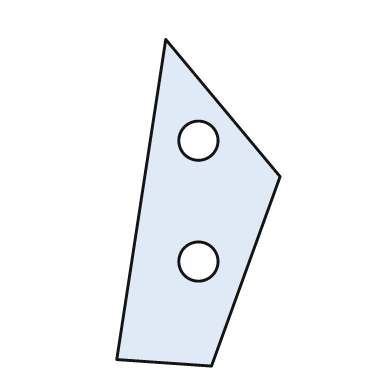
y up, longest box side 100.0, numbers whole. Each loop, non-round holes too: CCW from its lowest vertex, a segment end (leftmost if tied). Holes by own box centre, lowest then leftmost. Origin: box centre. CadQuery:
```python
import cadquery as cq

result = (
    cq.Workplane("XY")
    .moveTo(4.0, -50.0)
    .lineTo(25.0, 8.0)
    .lineTo(-10.0, 50.0)
    .lineTo(-25.0, -48.0)
    .close()
    .moveTo(0.0, -18.0)
    .circle(6.0)
    .moveTo(0.0, 19.0)
    .circle(6.0)
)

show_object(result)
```